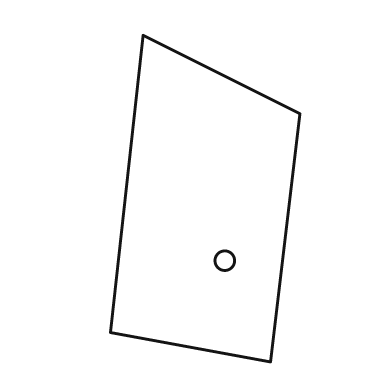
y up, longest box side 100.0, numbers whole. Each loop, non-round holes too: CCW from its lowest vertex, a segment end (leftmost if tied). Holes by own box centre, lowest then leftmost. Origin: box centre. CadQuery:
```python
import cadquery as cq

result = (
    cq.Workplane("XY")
    .moveTo(20.0, -50.0)
    .lineTo(29.0, 26.0)
    .lineTo(-19.0, 50.0)
    .lineTo(-29.0, -41.0)
    .close()
    .moveTo(6.0, -19.0)
    .circle(3.0)
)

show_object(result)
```